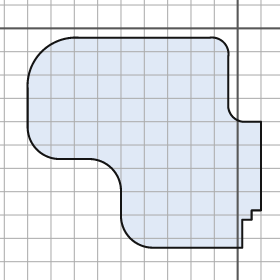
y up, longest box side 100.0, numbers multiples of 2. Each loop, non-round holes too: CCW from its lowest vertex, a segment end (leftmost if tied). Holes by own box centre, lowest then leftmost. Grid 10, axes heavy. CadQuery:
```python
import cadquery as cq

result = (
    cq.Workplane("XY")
    .moveTo(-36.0, -94.0)
    .lineTo(2.0, -94.0)
    .lineTo(2.0, -82.0)
    .lineTo(6.0, -82.0)
    .lineTo(6.0, -78.0)
    .lineTo(10.0, -78.0)
    .lineTo(10.0, -40.0)
    .lineTo(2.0, -40.0)
    .threePointArc((-2.0, -38.0), (-4.0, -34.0))
    .lineTo(-4.0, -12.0)
    .threePointArc((-6.0, -6.0), (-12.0, -4.0))
    .lineTo(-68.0, -4.0)
    .threePointArc((-84.0, -10.0), (-90.0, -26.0))
    .lineTo(-90.0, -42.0)
    .threePointArc((-86.0, -52.0), (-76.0, -56.0))
    .lineTo(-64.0, -56.0)
    .threePointArc((-54.0, -60.0), (-50.0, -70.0))
    .lineTo(-50.0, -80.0)
    .threePointArc((-46.0, -90.0), (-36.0, -94.0))
    .close()
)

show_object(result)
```